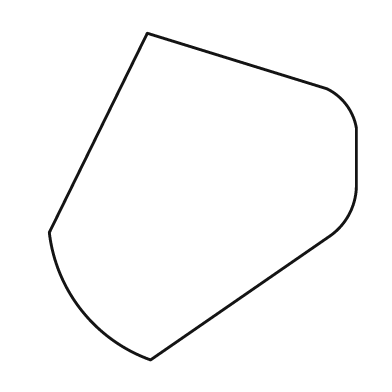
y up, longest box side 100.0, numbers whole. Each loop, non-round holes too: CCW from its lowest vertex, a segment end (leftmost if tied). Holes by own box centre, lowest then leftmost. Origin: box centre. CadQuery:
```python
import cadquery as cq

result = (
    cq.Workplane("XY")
    .moveTo(-16.0, -50.0)
    .lineTo(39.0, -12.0)
    .threePointArc((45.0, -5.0), (47.0, 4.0))
    .lineTo(47.0, 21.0)
    .threePointArc((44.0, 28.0), (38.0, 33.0))
    .lineTo(-17.0, 50.0)
    .lineTo(-47.0, -11.0)
    .threePointArc((-37.0, -35.0), (-16.0, -50.0))
    .close()
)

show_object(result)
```